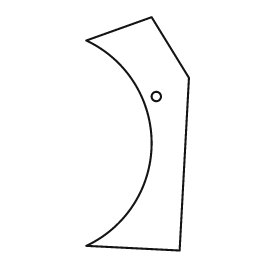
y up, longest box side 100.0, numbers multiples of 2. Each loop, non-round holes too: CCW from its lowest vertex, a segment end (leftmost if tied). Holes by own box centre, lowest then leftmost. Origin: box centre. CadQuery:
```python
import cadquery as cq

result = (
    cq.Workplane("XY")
    .moveTo(18.0, -50.0)
    .lineTo(22.0, 24.0)
    .lineTo(6.0, 50.0)
    .lineTo(-22.0, 40.0)
    .threePointArc((6.0, -4.0), (-22.0, -48.0))
    .close()
    .moveTo(8.0, 16.0)
    .circle(2.0)
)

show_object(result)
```